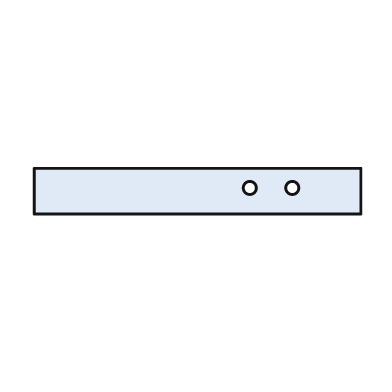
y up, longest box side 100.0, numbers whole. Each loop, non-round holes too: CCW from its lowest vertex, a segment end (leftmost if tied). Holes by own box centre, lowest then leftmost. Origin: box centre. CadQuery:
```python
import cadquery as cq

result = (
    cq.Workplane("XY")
    .moveTo(-50.0, -7.0)
    .lineTo(50.0, -7.0)
    .lineTo(50.0, 7.0)
    .lineTo(-50.0, 7.0)
    .close()
    .moveTo(16.0, 1.0)
    .circle(2.0)
    .moveTo(29.0, 1.0)
    .circle(2.0)
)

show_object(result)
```